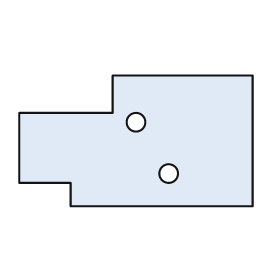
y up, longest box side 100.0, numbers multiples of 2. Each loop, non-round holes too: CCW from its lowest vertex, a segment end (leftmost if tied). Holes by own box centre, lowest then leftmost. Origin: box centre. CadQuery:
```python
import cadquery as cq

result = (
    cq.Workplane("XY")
    .moveTo(-28.0, -28.0)
    .lineTo(50.0, -28.0)
    .lineTo(50.0, 28.0)
    .lineTo(-10.0, 28.0)
    .lineTo(-10.0, 12.0)
    .lineTo(-50.0, 12.0)
    .lineTo(-50.0, -18.0)
    .lineTo(-28.0, -18.0)
    .close()
    .moveTo(14.0, -14.0)
    .circle(4.0)
    .moveTo(0.0, 8.0)
    .circle(4.0)
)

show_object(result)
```